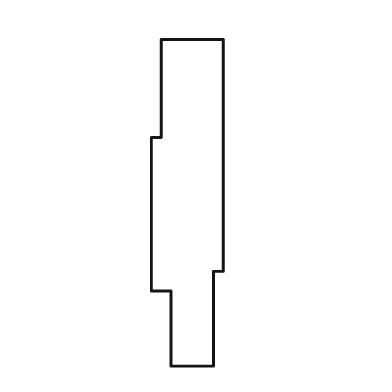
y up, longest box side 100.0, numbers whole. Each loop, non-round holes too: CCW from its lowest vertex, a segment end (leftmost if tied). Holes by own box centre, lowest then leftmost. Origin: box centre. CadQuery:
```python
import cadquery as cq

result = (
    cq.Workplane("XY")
    .moveTo(-5.0, -50.0)
    .lineTo(8.0, -50.0)
    .lineTo(8.0, -21.0)
    .lineTo(11.0, -21.0)
    .lineTo(11.0, 50.0)
    .lineTo(-8.0, 50.0)
    .lineTo(-8.0, 20.0)
    .lineTo(-11.0, 20.0)
    .lineTo(-11.0, -27.0)
    .lineTo(-5.0, -27.0)
    .close()
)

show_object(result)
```